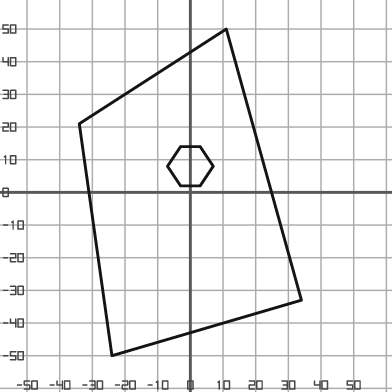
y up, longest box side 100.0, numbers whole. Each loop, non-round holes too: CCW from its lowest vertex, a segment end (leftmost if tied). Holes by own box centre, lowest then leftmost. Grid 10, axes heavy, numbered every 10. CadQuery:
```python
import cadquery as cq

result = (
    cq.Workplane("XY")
    .moveTo(-24.0, -50.0)
    .lineTo(34.0, -33.0)
    .lineTo(11.0, 50.0)
    .lineTo(-34.0, 21.0)
    .close()
    .moveTo(-3.0, 2.0)
    .lineTo(3.0, 2.0)
    .lineTo(7.0, 8.0)
    .lineTo(3.0, 14.0)
    .lineTo(-3.0, 14.0)
    .lineTo(-7.0, 8.0)
    .close()
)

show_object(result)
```